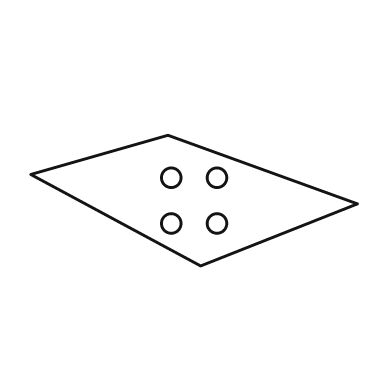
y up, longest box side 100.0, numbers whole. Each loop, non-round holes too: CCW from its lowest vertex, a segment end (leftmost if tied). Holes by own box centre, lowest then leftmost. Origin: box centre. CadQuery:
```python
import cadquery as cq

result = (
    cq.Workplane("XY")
    .moveTo(2.0, -20.0)
    .lineTo(50.0, -1.0)
    .lineTo(-8.0, 20.0)
    .lineTo(-50.0, 8.0)
    .close()
    .moveTo(-7.0, -7.0)
    .circle(3.0)
    .moveTo(7.0, -7.0)
    .circle(3.0)
    .moveTo(-7.0, 7.0)
    .circle(3.0)
    .moveTo(7.0, 7.0)
    .circle(3.0)
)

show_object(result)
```